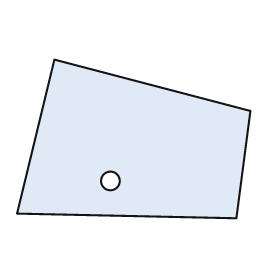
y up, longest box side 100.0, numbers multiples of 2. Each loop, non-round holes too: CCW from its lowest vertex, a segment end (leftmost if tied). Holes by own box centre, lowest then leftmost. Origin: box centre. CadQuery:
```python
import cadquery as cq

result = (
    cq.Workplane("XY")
    .moveTo(44.0, -34.0)
    .lineTo(50.0, 12.0)
    .lineTo(-34.0, 34.0)
    .lineTo(-50.0, -32.0)
    .close()
    .moveTo(-10.0, -18.0)
    .circle(4.0)
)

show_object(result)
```